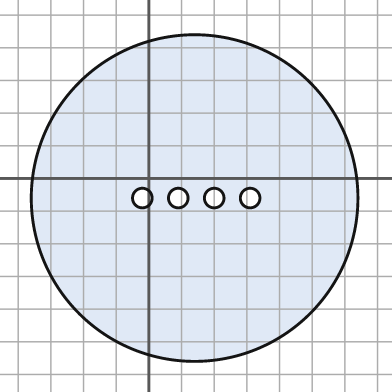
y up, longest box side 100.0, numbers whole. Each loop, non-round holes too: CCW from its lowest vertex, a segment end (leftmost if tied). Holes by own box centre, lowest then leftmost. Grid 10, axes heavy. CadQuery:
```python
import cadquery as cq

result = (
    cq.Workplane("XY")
    .moveTo(14.0, -6.0)
    .circle(50.0)
    .moveTo(-2.0, -6.0)
    .circle(3.0)
    .moveTo(9.0, -6.0)
    .circle(3.0)
    .moveTo(20.0, -6.0)
    .circle(3.0)
    .moveTo(31.0, -6.0)
    .circle(3.0)
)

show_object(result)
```